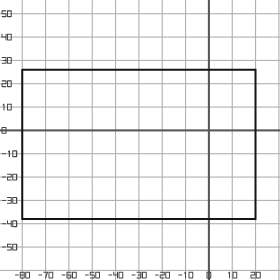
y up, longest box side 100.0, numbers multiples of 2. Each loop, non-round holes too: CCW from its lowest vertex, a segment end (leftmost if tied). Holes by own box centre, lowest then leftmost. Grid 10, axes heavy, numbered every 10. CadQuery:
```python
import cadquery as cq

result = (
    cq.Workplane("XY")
    .moveTo(-80.0, -38.0)
    .lineTo(20.0, -38.0)
    .lineTo(20.0, 26.0)
    .lineTo(-80.0, 26.0)
    .close()
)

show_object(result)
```